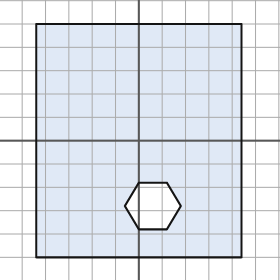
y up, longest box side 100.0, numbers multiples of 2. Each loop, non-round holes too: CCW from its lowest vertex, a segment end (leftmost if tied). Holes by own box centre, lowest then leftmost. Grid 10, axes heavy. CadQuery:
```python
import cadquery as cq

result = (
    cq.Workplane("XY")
    .moveTo(-44.0, -50.0)
    .lineTo(44.0, -50.0)
    .lineTo(44.0, 50.0)
    .lineTo(-44.0, 50.0)
    .close()
    .moveTo(0.0, -38.0)
    .lineTo(12.0, -38.0)
    .lineTo(18.0, -28.0)
    .lineTo(12.0, -18.0)
    .lineTo(0.0, -18.0)
    .lineTo(-6.0, -28.0)
    .close()
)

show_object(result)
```